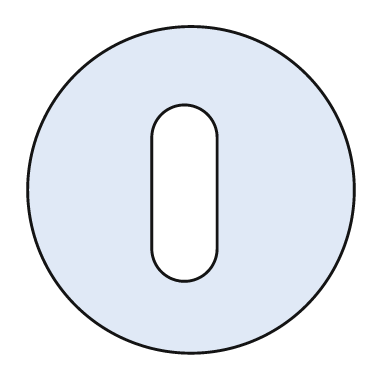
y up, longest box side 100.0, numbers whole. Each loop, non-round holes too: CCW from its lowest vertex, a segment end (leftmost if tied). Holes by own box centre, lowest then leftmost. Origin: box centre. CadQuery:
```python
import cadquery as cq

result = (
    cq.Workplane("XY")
    .moveTo(0.0, 0.0)
    .circle(50.0)
    .moveTo(-12.0, -18.0)
    .threePointArc((-2.0, -28.0), (8.0, -18.0))
    .lineTo(8.0, 16.0)
    .threePointArc((-2.0, 26.0), (-12.0, 16.0))
    .close()
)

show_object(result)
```